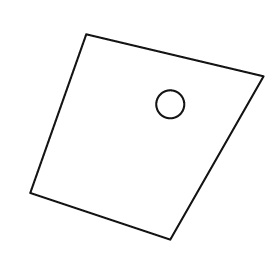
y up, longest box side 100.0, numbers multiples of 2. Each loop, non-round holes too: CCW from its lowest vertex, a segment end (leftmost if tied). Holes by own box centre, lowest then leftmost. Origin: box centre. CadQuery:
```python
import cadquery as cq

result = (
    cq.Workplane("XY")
    .moveTo(10.0, -44.0)
    .lineTo(50.0, 26.0)
    .lineTo(-26.0, 44.0)
    .lineTo(-50.0, -24.0)
    .close()
    .moveTo(10.0, 14.0)
    .circle(6.0)
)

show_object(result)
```